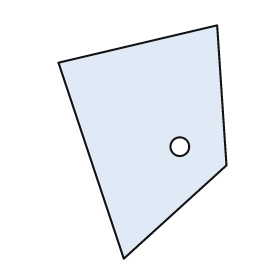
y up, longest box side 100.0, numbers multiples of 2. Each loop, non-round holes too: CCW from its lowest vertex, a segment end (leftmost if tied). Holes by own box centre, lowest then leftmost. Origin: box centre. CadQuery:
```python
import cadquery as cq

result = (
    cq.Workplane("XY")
    .moveTo(-8.0, -50.0)
    .lineTo(36.0, -10.0)
    .lineTo(32.0, 50.0)
    .lineTo(-36.0, 34.0)
    .close()
    .moveTo(16.0, -2.0)
    .circle(4.0)
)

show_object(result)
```